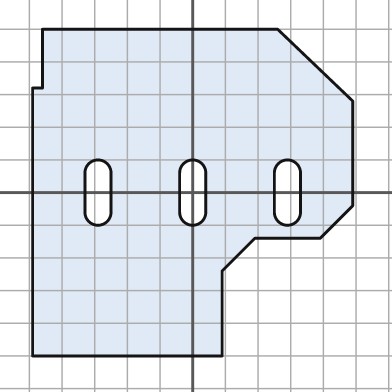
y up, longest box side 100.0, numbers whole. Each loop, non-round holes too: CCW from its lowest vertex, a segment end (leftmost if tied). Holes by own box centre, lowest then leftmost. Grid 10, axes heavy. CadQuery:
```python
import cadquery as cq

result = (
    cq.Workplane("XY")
    .moveTo(-49.0, -50.0)
    .lineTo(9.0, -50.0)
    .lineTo(9.0, -24.0)
    .lineTo(19.0, -14.0)
    .lineTo(39.0, -14.0)
    .lineTo(49.0, -4.0)
    .lineTo(49.0, 28.0)
    .lineTo(26.0, 50.0)
    .lineTo(-46.0, 50.0)
    .lineTo(-46.0, 32.0)
    .lineTo(-49.0, 32.0)
    .close()
    .moveTo(-33.0, -6.0)
    .threePointArc((-29.0, -10.0), (-25.0, -6.0))
    .lineTo(-25.0, 6.0)
    .threePointArc((-29.0, 10.0), (-33.0, 6.0))
    .close()
    .moveTo(-4.0, -6.0)
    .threePointArc((0.0, -10.0), (4.0, -6.0))
    .lineTo(4.0, 6.0)
    .threePointArc((0.0, 10.0), (-4.0, 6.0))
    .close()
    .moveTo(25.0, -6.0)
    .threePointArc((29.0, -10.0), (33.0, -6.0))
    .lineTo(33.0, 6.0)
    .threePointArc((29.0, 10.0), (25.0, 6.0))
    .close()
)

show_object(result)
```